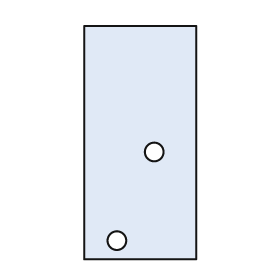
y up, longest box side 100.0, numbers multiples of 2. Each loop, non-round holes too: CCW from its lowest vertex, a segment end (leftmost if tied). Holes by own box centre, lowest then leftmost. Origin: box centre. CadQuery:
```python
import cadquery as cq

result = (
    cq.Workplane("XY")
    .moveTo(-24.0, -50.0)
    .lineTo(24.0, -50.0)
    .lineTo(24.0, 50.0)
    .lineTo(-24.0, 50.0)
    .close()
    .moveTo(-10.0, -42.0)
    .circle(4.0)
    .moveTo(6.0, -4.0)
    .circle(4.0)
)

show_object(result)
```